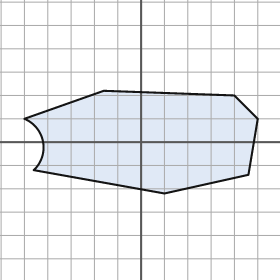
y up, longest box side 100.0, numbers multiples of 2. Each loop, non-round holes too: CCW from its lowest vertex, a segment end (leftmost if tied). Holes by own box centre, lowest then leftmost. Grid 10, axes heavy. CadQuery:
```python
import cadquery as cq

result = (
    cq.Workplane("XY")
    .moveTo(10.0, -22.0)
    .lineTo(46.0, -14.0)
    .lineTo(50.0, 10.0)
    .lineTo(40.0, 20.0)
    .lineTo(-16.0, 22.0)
    .lineTo(-50.0, 10.0)
    .threePointArc((-42.0, 0.0), (-46.0, -12.0))
    .close()
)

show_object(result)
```